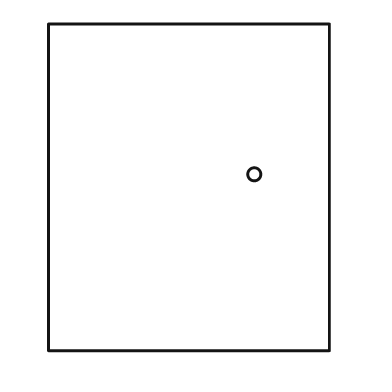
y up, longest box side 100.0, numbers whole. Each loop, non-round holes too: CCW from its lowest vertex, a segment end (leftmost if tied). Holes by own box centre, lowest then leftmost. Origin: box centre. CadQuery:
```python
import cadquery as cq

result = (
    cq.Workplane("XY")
    .moveTo(-43.0, -50.0)
    .lineTo(43.0, -50.0)
    .lineTo(43.0, 50.0)
    .lineTo(-43.0, 50.0)
    .close()
    .moveTo(20.0, 4.0)
    .circle(2.0)
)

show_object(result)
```